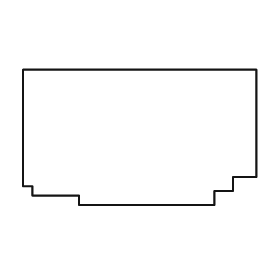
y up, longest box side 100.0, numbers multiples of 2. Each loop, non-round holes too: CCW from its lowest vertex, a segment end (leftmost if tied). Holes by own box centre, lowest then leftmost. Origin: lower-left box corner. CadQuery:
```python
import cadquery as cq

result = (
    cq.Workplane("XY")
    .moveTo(24.0, 0.0)
    .lineTo(82.0, 0.0)
    .lineTo(82.0, 6.0)
    .lineTo(90.0, 6.0)
    .lineTo(90.0, 12.0)
    .lineTo(100.0, 12.0)
    .lineTo(100.0, 58.0)
    .lineTo(0.0, 58.0)
    .lineTo(0.0, 8.0)
    .lineTo(4.0, 8.0)
    .lineTo(4.0, 4.0)
    .lineTo(24.0, 4.0)
    .close()
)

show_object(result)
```